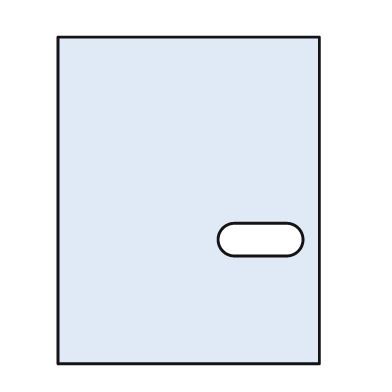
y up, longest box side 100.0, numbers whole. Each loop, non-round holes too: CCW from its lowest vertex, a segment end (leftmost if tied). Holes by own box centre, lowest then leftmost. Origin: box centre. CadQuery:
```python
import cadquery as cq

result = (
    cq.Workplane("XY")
    .moveTo(-40.0, -50.0)
    .lineTo(40.0, -50.0)
    .lineTo(40.0, 50.0)
    .lineTo(-40.0, 50.0)
    .close()
    .moveTo(14.0, -17.0)
    .lineTo(30.0, -17.0)
    .threePointArc((35.0, -12.0), (30.0, -7.0))
    .lineTo(14.0, -7.0)
    .threePointArc((9.0, -12.0), (14.0, -17.0))
    .close()
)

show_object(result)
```